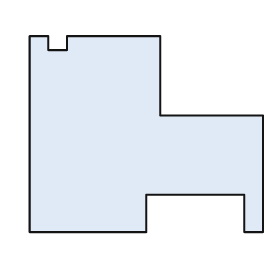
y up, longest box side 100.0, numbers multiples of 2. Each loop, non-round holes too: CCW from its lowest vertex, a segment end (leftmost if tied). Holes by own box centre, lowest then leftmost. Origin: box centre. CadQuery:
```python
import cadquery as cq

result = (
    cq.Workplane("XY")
    .moveTo(-50.0, -42.0)
    .lineTo(0.0, -42.0)
    .lineTo(0.0, -26.0)
    .lineTo(42.0, -26.0)
    .lineTo(42.0, -42.0)
    .lineTo(50.0, -42.0)
    .lineTo(50.0, 8.0)
    .lineTo(6.0, 8.0)
    .lineTo(6.0, 42.0)
    .lineTo(-34.0, 42.0)
    .lineTo(-34.0, 36.0)
    .lineTo(-42.0, 36.0)
    .lineTo(-42.0, 42.0)
    .lineTo(-50.0, 42.0)
    .close()
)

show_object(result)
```